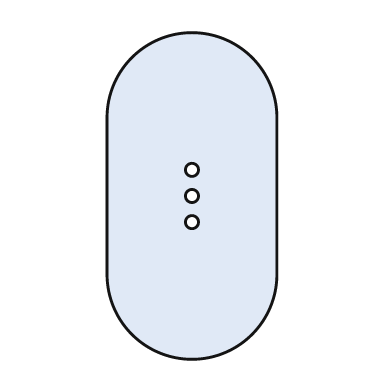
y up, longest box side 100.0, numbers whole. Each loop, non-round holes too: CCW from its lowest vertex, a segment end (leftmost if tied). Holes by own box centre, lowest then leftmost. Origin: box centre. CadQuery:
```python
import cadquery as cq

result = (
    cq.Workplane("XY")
    .moveTo(-26.0, -24.0)
    .threePointArc((0.0, -50.0), (26.0, -24.0))
    .lineTo(26.0, 24.0)
    .threePointArc((0.0, 50.0), (-26.0, 24.0))
    .close()
    .moveTo(0.0, -8.0)
    .circle(2.0)
    .moveTo(0.0, 0.0)
    .circle(2.0)
    .moveTo(0.0, 8.0)
    .circle(2.0)
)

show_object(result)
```